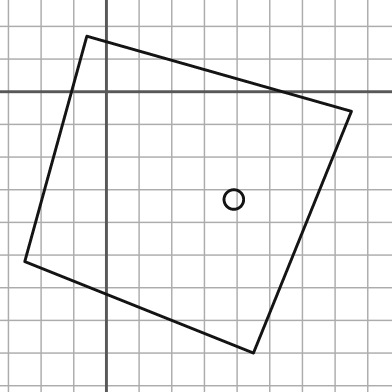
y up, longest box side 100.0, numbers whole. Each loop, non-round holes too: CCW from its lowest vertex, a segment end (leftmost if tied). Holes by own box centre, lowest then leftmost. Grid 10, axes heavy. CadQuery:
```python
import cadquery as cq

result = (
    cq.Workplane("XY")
    .moveTo(45.0, -80.0)
    .lineTo(75.0, -6.0)
    .lineTo(-6.0, 17.0)
    .lineTo(-25.0, -52.0)
    .close()
    .moveTo(39.0, -33.0)
    .circle(3.0)
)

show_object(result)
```